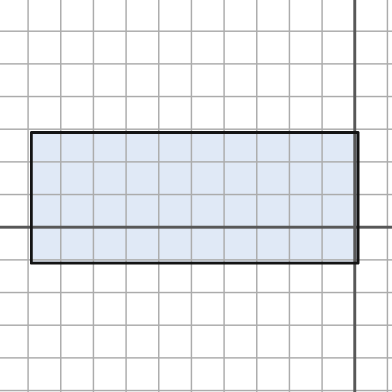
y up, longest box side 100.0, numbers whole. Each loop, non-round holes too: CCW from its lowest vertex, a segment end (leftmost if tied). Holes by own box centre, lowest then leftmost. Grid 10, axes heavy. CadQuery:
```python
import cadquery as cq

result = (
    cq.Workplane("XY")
    .moveTo(-99.0, -11.0)
    .lineTo(1.0, -11.0)
    .lineTo(1.0, 29.0)
    .lineTo(-99.0, 29.0)
    .close()
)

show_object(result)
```